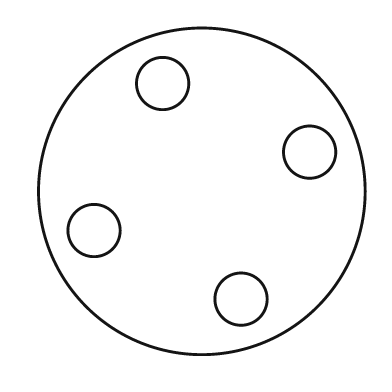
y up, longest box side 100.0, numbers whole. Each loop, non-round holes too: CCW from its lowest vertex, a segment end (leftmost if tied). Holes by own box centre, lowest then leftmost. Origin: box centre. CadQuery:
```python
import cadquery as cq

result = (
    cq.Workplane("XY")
    .moveTo(0.0, 0.0)
    .circle(50.0)
    .moveTo(12.0, -33.0)
    .circle(8.0)
    .moveTo(-33.0, -12.0)
    .circle(8.0)
    .moveTo(33.0, 12.0)
    .circle(8.0)
    .moveTo(-12.0, 33.0)
    .circle(8.0)
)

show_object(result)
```